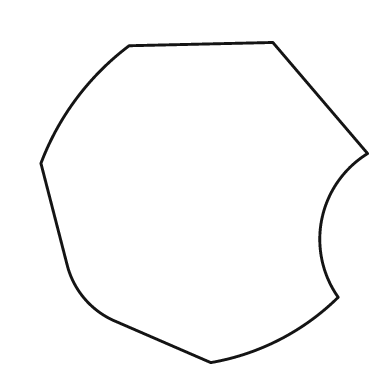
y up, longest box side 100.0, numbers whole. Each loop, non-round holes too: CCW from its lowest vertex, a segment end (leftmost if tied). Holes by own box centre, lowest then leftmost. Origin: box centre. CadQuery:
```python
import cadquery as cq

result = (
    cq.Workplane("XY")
    .moveTo(2.0, -49.0)
    .threePointArc((23.0, -42.0), (41.0, -29.0))
    .threePointArc((36.0, -5.0), (50.0, 15.0))
    .lineTo(21.0, 49.0)
    .lineTo(-23.0, 48.0)
    .threePointArc((-39.0, 32.0), (-50.0, 12.0))
    .lineTo(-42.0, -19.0)
    .threePointArc((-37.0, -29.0), (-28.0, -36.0))
    .close()
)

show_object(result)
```